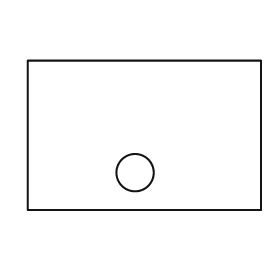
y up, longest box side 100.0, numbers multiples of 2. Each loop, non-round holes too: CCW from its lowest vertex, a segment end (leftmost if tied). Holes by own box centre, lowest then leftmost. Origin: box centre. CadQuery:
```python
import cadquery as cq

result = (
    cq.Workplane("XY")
    .moveTo(-50.0, -32.0)
    .lineTo(50.0, -32.0)
    .lineTo(50.0, 32.0)
    .lineTo(-50.0, 32.0)
    .close()
    .moveTo(-4.0, -16.0)
    .circle(8.0)
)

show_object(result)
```